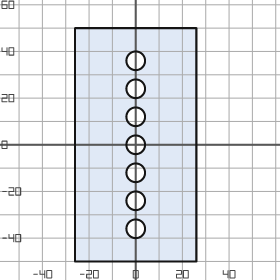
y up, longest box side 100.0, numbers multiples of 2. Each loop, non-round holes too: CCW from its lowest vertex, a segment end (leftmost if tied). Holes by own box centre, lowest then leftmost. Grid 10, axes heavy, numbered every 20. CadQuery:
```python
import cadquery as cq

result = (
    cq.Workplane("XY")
    .moveTo(-26.0, -50.0)
    .lineTo(26.0, -50.0)
    .lineTo(26.0, 50.0)
    .lineTo(-26.0, 50.0)
    .close()
    .moveTo(0.0, -36.0)
    .circle(4.0)
    .moveTo(0.0, -24.0)
    .circle(4.0)
    .moveTo(0.0, -12.0)
    .circle(4.0)
    .moveTo(0.0, 0.0)
    .circle(4.0)
    .moveTo(0.0, 12.0)
    .circle(4.0)
    .moveTo(0.0, 24.0)
    .circle(4.0)
    .moveTo(0.0, 36.0)
    .circle(4.0)
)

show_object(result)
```